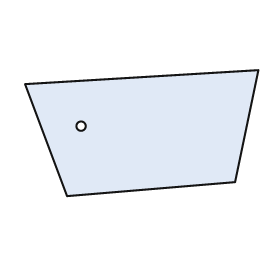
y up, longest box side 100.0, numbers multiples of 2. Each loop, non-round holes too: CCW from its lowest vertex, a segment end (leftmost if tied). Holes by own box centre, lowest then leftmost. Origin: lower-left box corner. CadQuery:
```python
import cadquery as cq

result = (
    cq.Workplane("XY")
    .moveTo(18.0, 0.0)
    .lineTo(90.0, 6.0)
    .lineTo(100.0, 54.0)
    .lineTo(0.0, 48.0)
    .close()
    .moveTo(24.0, 30.0)
    .circle(2.0)
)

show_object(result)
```